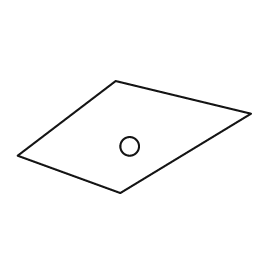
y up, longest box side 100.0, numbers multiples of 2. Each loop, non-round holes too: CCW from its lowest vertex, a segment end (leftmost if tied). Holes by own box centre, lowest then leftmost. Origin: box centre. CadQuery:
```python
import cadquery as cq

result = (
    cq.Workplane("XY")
    .moveTo(-6.0, -24.0)
    .lineTo(50.0, 10.0)
    .lineTo(-8.0, 24.0)
    .lineTo(-50.0, -8.0)
    .close()
    .moveTo(-2.0, -4.0)
    .circle(4.0)
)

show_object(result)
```